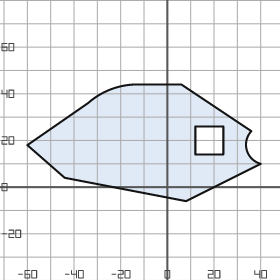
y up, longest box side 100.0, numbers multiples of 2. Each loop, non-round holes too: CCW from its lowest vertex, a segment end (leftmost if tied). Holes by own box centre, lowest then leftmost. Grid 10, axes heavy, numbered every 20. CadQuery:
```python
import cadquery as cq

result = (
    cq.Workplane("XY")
    .moveTo(8.0, -6.0)
    .lineTo(40.0, 10.0)
    .threePointArc((34.0, 16.0), (36.0, 24.0))
    .lineTo(6.0, 44.0)
    .lineTo(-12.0, 44.0)
    .threePointArc((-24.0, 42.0), (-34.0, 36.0))
    .lineTo(-60.0, 18.0)
    .lineTo(-44.0, 4.0)
    .close()
    .moveTo(12.0, 14.0)
    .lineTo(24.0, 14.0)
    .lineTo(24.0, 26.0)
    .lineTo(12.0, 26.0)
    .close()
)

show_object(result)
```